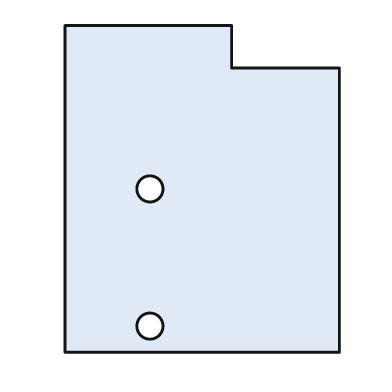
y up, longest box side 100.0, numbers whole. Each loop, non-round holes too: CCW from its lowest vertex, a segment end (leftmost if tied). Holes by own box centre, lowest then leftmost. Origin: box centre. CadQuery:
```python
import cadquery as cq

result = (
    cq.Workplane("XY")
    .moveTo(-42.0, -50.0)
    .lineTo(42.0, -50.0)
    .lineTo(42.0, 37.0)
    .lineTo(9.0, 37.0)
    .lineTo(9.0, 50.0)
    .lineTo(-42.0, 50.0)
    .close()
    .moveTo(-16.0, -42.0)
    .circle(4.0)
    .moveTo(-16.0, 0.0)
    .circle(4.0)
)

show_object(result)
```